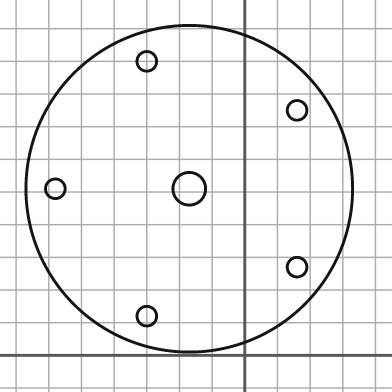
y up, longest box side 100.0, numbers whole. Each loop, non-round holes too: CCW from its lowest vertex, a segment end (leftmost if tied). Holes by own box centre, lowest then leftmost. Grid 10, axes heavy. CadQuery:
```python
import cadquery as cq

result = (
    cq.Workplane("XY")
    .moveTo(-17.0, 51.0)
    .circle(50.0)
    .moveTo(-30.0, 12.0)
    .circle(3.0)
    .moveTo(16.0, 27.0)
    .circle(3.0)
    .moveTo(-58.0, 51.0)
    .circle(3.0)
    .moveTo(-17.0, 51.0)
    .circle(5.0)
    .moveTo(16.0, 75.0)
    .circle(3.0)
    .moveTo(-30.0, 90.0)
    .circle(3.0)
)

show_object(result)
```